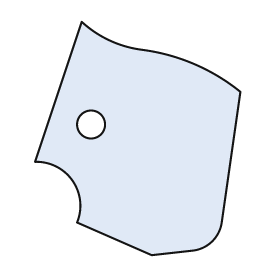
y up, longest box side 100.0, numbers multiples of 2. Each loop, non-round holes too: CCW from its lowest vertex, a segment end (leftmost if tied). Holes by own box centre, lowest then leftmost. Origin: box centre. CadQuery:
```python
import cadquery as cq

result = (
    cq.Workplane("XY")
    .moveTo(6.0, -50.0)
    .lineTo(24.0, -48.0)
    .threePointArc((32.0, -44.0), (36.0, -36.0))
    .lineTo(44.0, 20.0)
    .threePointArc((24.0, 32.0), (2.0, 38.0))
    .threePointArc((-12.0, 42.0), (-24.0, 50.0))
    .lineTo(-44.0, -10.0)
    .threePointArc((-28.0, -18.0), (-26.0, -36.0))
    .close()
    .moveTo(-20.0, 6.0)
    .circle(6.0)
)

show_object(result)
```